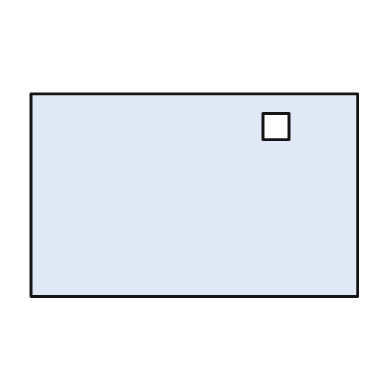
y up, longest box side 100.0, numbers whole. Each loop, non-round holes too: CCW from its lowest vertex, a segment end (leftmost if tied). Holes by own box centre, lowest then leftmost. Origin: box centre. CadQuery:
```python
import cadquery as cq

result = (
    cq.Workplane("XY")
    .moveTo(-50.0, -31.0)
    .lineTo(50.0, -31.0)
    .lineTo(50.0, 31.0)
    .lineTo(-50.0, 31.0)
    .close()
    .moveTo(21.0, 17.0)
    .lineTo(29.0, 17.0)
    .lineTo(29.0, 25.0)
    .lineTo(21.0, 25.0)
    .close()
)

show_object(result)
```